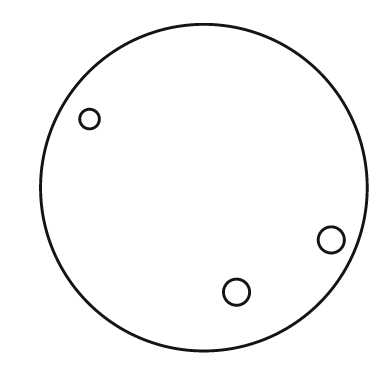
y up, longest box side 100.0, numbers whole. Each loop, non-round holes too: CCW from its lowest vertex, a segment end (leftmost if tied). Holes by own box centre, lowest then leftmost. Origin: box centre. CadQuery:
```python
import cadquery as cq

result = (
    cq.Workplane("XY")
    .moveTo(0.0, 0.0)
    .circle(50.0)
    .moveTo(10.0, -32.0)
    .circle(4.0)
    .moveTo(39.0, -16.0)
    .circle(4.0)
    .moveTo(-35.0, 21.0)
    .circle(3.0)
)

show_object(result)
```